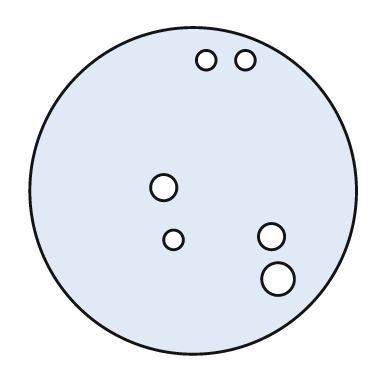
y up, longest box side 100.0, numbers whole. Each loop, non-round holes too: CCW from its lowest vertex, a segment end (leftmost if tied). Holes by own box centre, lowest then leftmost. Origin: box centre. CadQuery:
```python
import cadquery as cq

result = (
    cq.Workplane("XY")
    .moveTo(0.0, 0.0)
    .circle(50.0)
    .moveTo(26.0, -27.0)
    .circle(5.0)
    .moveTo(-6.0, -15.0)
    .circle(3.0)
    .moveTo(24.0, -14.0)
    .circle(4.0)
    .moveTo(-9.0, 1.0)
    .circle(4.0)
    .moveTo(4.0, 40.0)
    .circle(3.0)
    .moveTo(16.0, 40.0)
    .circle(3.0)
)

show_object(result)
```